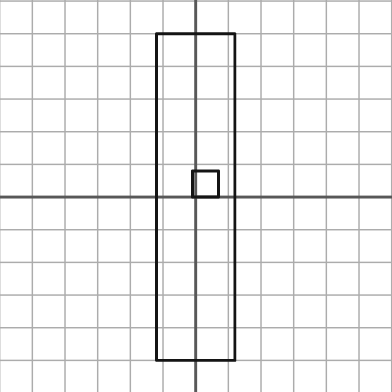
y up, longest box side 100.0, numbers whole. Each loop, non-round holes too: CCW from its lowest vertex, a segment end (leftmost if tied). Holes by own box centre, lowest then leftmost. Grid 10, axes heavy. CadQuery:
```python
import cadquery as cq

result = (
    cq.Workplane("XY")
    .moveTo(-12.0, -50.0)
    .lineTo(12.0, -50.0)
    .lineTo(12.0, 50.0)
    .lineTo(-12.0, 50.0)
    .close()
    .moveTo(-1.0, 0.0)
    .lineTo(7.0, 0.0)
    .lineTo(7.0, 8.0)
    .lineTo(-1.0, 8.0)
    .close()
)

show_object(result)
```